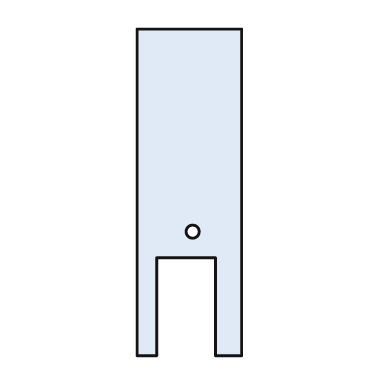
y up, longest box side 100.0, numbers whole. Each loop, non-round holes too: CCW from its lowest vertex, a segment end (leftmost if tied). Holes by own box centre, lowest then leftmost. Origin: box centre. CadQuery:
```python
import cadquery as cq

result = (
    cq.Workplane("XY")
    .moveTo(-16.0, -50.0)
    .lineTo(-10.0, -50.0)
    .lineTo(-10.0, -20.0)
    .lineTo(8.0, -20.0)
    .lineTo(8.0, -50.0)
    .lineTo(16.0, -50.0)
    .lineTo(16.0, 50.0)
    .lineTo(-16.0, 50.0)
    .close()
    .moveTo(1.0, -12.0)
    .circle(2.0)
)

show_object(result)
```